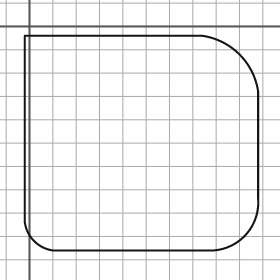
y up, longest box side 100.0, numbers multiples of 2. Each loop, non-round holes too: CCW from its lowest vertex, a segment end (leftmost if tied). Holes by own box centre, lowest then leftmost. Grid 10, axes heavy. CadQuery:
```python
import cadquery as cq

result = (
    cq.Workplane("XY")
    .moveTo(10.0, -96.0)
    .lineTo(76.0, -96.0)
    .threePointArc((92.0, -90.0), (98.0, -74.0))
    .lineTo(98.0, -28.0)
    .threePointArc((90.0, -12.0), (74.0, -4.0))
    .lineTo(-2.0, -4.0)
    .lineTo(-2.0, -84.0)
    .threePointArc((2.0, -92.0), (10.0, -96.0))
    .close()
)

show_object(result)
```